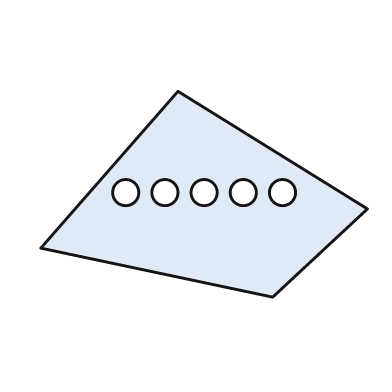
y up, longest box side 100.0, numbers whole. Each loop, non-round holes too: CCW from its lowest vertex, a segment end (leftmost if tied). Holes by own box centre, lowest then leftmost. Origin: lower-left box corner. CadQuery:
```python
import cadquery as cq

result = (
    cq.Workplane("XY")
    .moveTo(71.0, 0.0)
    .lineTo(100.0, 27.0)
    .lineTo(42.0, 63.0)
    .lineTo(0.0, 15.0)
    .close()
    .moveTo(26.0, 32.0)
    .circle(4.0)
    .moveTo(38.0, 32.0)
    .circle(4.0)
    .moveTo(50.0, 32.0)
    .circle(4.0)
    .moveTo(62.0, 32.0)
    .circle(4.0)
    .moveTo(74.0, 32.0)
    .circle(4.0)
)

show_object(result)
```